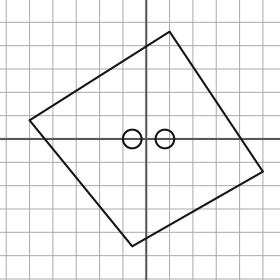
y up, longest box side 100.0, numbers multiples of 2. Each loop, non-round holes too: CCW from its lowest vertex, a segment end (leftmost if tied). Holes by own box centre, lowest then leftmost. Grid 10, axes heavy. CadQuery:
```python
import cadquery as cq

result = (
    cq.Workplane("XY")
    .moveTo(-6.0, -46.0)
    .lineTo(50.0, -14.0)
    .lineTo(10.0, 46.0)
    .lineTo(-50.0, 8.0)
    .close()
    .moveTo(-6.0, 0.0)
    .circle(4.0)
    .moveTo(8.0, 0.0)
    .circle(4.0)
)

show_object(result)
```